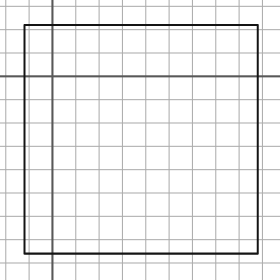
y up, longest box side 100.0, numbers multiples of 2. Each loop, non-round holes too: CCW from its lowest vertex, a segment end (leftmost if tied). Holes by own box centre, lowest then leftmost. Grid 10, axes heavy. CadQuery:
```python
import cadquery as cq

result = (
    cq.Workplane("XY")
    .moveTo(-12.0, -76.0)
    .lineTo(88.0, -76.0)
    .lineTo(88.0, 22.0)
    .lineTo(-12.0, 22.0)
    .close()
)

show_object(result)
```